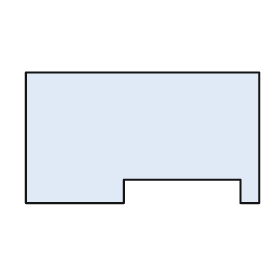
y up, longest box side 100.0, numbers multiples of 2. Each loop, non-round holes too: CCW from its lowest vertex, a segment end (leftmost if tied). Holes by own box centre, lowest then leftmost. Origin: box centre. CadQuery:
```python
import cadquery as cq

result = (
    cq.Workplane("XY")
    .moveTo(-50.0, -28.0)
    .lineTo(-8.0, -28.0)
    .lineTo(-8.0, -18.0)
    .lineTo(42.0, -18.0)
    .lineTo(42.0, -28.0)
    .lineTo(50.0, -28.0)
    .lineTo(50.0, 28.0)
    .lineTo(-50.0, 28.0)
    .close()
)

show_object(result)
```